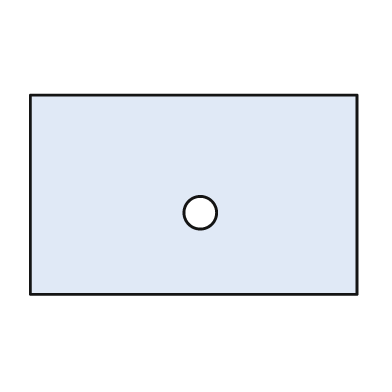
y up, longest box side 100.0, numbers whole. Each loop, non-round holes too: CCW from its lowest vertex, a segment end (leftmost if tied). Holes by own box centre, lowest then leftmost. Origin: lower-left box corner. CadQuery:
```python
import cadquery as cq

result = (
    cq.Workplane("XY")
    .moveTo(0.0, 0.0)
    .lineTo(100.0, 0.0)
    .lineTo(100.0, 61.0)
    .lineTo(0.0, 61.0)
    .close()
    .moveTo(52.0, 25.0)
    .circle(5.0)
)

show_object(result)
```